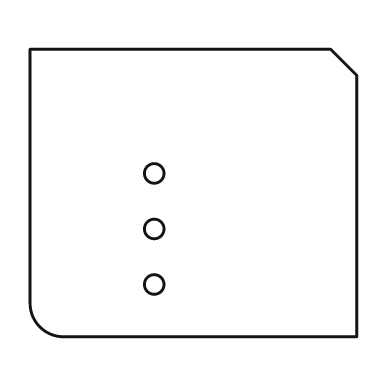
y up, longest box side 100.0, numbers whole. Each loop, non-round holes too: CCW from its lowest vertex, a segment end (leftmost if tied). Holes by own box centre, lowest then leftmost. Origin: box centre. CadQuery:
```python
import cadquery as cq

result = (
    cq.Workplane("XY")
    .moveTo(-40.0, -44.0)
    .lineTo(50.0, -44.0)
    .lineTo(50.0, 36.0)
    .lineTo(42.0, 44.0)
    .lineTo(-50.0, 44.0)
    .lineTo(-50.0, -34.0)
    .threePointArc((-47.0, -41.0), (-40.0, -44.0))
    .close()
    .moveTo(-12.0, -28.0)
    .circle(3.0)
    .moveTo(-12.0, -11.0)
    .circle(3.0)
    .moveTo(-12.0, 6.0)
    .circle(3.0)
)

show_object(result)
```